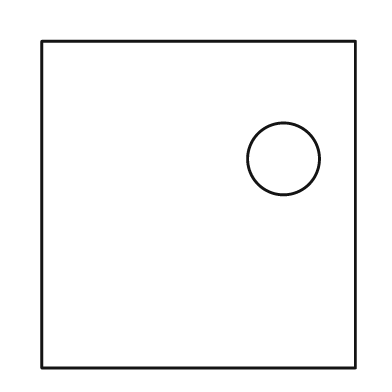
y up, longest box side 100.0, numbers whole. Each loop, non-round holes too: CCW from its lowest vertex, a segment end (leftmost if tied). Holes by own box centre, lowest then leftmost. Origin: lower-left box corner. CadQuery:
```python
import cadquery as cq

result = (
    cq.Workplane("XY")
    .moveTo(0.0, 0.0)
    .lineTo(96.0, 0.0)
    .lineTo(96.0, 100.0)
    .lineTo(0.0, 100.0)
    .close()
    .moveTo(74.0, 64.0)
    .circle(11.0)
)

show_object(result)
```